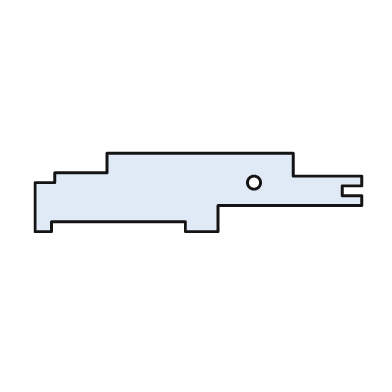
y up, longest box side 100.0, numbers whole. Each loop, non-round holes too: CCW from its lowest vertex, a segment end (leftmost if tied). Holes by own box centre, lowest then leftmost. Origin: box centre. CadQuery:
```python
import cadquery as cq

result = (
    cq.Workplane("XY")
    .moveTo(-50.0, -12.0)
    .lineTo(-45.0, -12.0)
    .lineTo(-45.0, -9.0)
    .lineTo(-4.0, -9.0)
    .lineTo(-4.0, -12.0)
    .lineTo(6.0, -12.0)
    .lineTo(6.0, -4.0)
    .lineTo(50.0, -4.0)
    .lineTo(50.0, -1.0)
    .lineTo(44.0, -1.0)
    .lineTo(44.0, 2.0)
    .lineTo(50.0, 2.0)
    .lineTo(50.0, 5.0)
    .lineTo(29.0, 5.0)
    .lineTo(29.0, 12.0)
    .lineTo(-28.0, 12.0)
    .lineTo(-28.0, 6.0)
    .lineTo(-44.0, 6.0)
    .lineTo(-44.0, 3.0)
    .lineTo(-50.0, 3.0)
    .close()
    .moveTo(17.0, 3.0)
    .circle(2.0)
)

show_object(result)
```